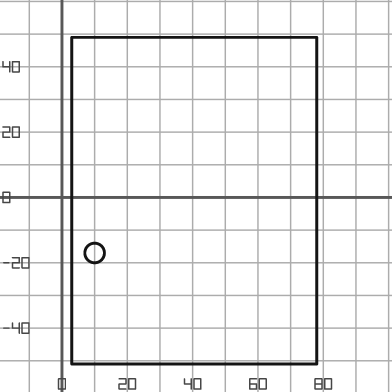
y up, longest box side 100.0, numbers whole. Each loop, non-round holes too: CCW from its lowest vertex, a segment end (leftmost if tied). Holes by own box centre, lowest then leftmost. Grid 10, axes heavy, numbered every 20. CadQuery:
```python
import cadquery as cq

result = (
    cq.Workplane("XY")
    .moveTo(3.0, -51.0)
    .lineTo(78.0, -51.0)
    .lineTo(78.0, 49.0)
    .lineTo(3.0, 49.0)
    .close()
    .moveTo(10.0, -17.0)
    .circle(3.0)
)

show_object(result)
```